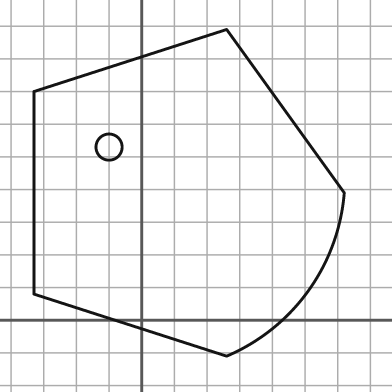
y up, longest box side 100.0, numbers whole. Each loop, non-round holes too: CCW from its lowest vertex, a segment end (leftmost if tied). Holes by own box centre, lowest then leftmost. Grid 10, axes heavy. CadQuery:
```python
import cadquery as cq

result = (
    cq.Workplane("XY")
    .moveTo(26.0, -11.0)
    .threePointArc((51.0, 9.0), (62.0, 39.0))
    .lineTo(26.0, 89.0)
    .lineTo(-33.0, 70.0)
    .lineTo(-33.0, 8.0)
    .close()
    .moveTo(-10.0, 53.0)
    .circle(4.0)
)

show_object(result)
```